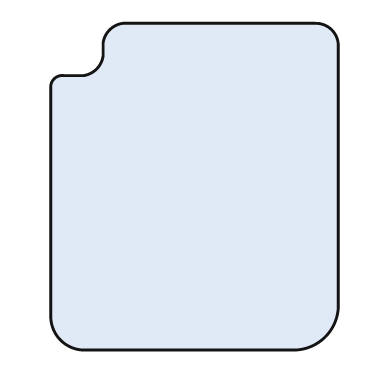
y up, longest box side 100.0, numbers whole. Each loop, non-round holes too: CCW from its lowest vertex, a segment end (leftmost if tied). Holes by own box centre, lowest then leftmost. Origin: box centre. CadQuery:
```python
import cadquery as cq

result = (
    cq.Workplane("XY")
    .moveTo(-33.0, -50.0)
    .lineTo(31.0, -50.0)
    .threePointArc((40.0, -46.0), (44.0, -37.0))
    .lineTo(44.0, 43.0)
    .threePointArc((42.0, 48.0), (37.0, 50.0))
    .lineTo(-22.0, 50.0)
    .threePointArc((-26.0, 48.0), (-28.0, 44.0))
    .lineTo(-28.0, 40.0)
    .threePointArc((-30.0, 36.0), (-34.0, 34.0))
    .lineTo(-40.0, 34.0)
    .threePointArc((-43.0, 33.0), (-44.0, 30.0))
    .lineTo(-44.0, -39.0)
    .threePointArc((-41.0, -47.0), (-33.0, -50.0))
    .close()
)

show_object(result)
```